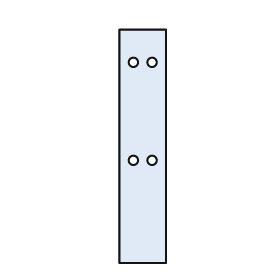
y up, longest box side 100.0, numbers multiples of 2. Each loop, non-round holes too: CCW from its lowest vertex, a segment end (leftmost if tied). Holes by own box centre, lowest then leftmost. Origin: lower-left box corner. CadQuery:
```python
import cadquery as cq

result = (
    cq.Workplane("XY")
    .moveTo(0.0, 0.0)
    .lineTo(20.0, 0.0)
    .lineTo(20.0, 100.0)
    .lineTo(0.0, 100.0)
    .close()
    .moveTo(6.0, 44.0)
    .circle(2.0)
    .moveTo(14.0, 44.0)
    .circle(2.0)
    .moveTo(6.0, 86.0)
    .circle(2.0)
    .moveTo(14.0, 86.0)
    .circle(2.0)
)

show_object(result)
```